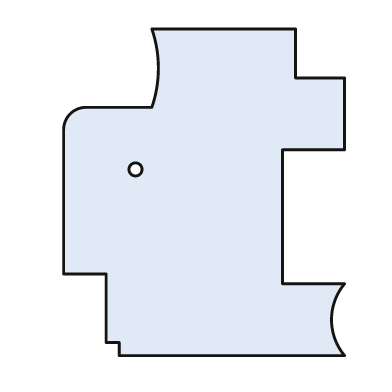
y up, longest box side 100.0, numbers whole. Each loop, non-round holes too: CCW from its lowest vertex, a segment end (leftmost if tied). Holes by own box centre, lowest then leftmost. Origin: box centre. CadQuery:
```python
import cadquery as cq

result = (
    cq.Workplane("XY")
    .moveTo(-26.0, -50.0)
    .lineTo(43.0, -50.0)
    .threePointArc((39.0, -39.0), (43.0, -28.0))
    .lineTo(24.0, -28.0)
    .lineTo(24.0, 13.0)
    .lineTo(43.0, 13.0)
    .lineTo(43.0, 35.0)
    .lineTo(28.0, 35.0)
    .lineTo(28.0, 50.0)
    .lineTo(-16.0, 50.0)
    .threePointArc((-14.0, 38.0), (-16.0, 26.0))
    .lineTo(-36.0, 26.0)
    .threePointArc((-41.0, 24.0), (-43.0, 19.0))
    .lineTo(-43.0, -25.0)
    .lineTo(-30.0, -25.0)
    .lineTo(-30.0, -46.0)
    .lineTo(-26.0, -46.0)
    .close()
    .moveTo(-21.0, 7.0)
    .circle(2.0)
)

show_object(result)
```